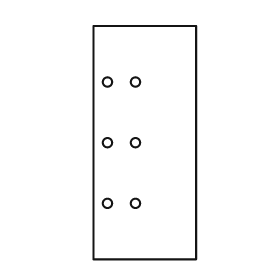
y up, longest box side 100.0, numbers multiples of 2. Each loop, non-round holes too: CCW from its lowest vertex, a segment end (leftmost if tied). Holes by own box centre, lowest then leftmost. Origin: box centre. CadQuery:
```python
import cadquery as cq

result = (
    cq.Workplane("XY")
    .moveTo(-22.0, -50.0)
    .lineTo(22.0, -50.0)
    .lineTo(22.0, 50.0)
    .lineTo(-22.0, 50.0)
    .close()
    .moveTo(-16.0, -26.0)
    .circle(2.0)
    .moveTo(-4.0, -26.0)
    .circle(2.0)
    .moveTo(-16.0, 0.0)
    .circle(2.0)
    .moveTo(-4.0, 0.0)
    .circle(2.0)
    .moveTo(-16.0, 26.0)
    .circle(2.0)
    .moveTo(-4.0, 26.0)
    .circle(2.0)
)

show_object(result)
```